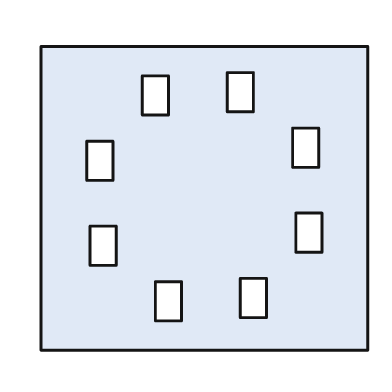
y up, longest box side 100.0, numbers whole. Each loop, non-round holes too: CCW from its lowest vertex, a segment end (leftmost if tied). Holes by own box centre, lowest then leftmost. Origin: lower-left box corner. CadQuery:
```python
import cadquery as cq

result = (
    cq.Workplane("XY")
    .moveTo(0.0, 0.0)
    .lineTo(100.0, 0.0)
    .lineTo(100.0, 93.0)
    .lineTo(0.0, 93.0)
    .close()
    .moveTo(35.0, 9.0)
    .lineTo(43.0, 9.0)
    .lineTo(43.0, 21.0)
    .lineTo(35.0, 21.0)
    .close()
    .moveTo(61.0, 10.0)
    .lineTo(69.0, 10.0)
    .lineTo(69.0, 22.0)
    .lineTo(61.0, 22.0)
    .close()
    .moveTo(15.0, 26.0)
    .lineTo(23.0, 26.0)
    .lineTo(23.0, 38.0)
    .lineTo(15.0, 38.0)
    .close()
    .moveTo(78.0, 30.0)
    .lineTo(86.0, 30.0)
    .lineTo(86.0, 42.0)
    .lineTo(78.0, 42.0)
    .close()
    .moveTo(14.0, 52.0)
    .lineTo(22.0, 52.0)
    .lineTo(22.0, 64.0)
    .lineTo(14.0, 64.0)
    .close()
    .moveTo(77.0, 56.0)
    .lineTo(85.0, 56.0)
    .lineTo(85.0, 68.0)
    .lineTo(77.0, 68.0)
    .close()
    .moveTo(31.0, 72.0)
    .lineTo(39.0, 72.0)
    .lineTo(39.0, 84.0)
    .lineTo(31.0, 84.0)
    .close()
    .moveTo(57.0, 73.0)
    .lineTo(65.0, 73.0)
    .lineTo(65.0, 85.0)
    .lineTo(57.0, 85.0)
    .close()
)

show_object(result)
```